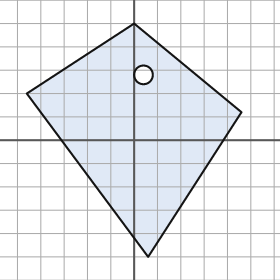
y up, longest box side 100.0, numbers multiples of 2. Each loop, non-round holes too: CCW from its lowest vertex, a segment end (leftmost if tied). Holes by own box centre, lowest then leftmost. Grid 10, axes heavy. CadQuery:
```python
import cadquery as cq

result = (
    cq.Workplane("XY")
    .moveTo(6.0, -50.0)
    .lineTo(46.0, 12.0)
    .lineTo(0.0, 50.0)
    .lineTo(-46.0, 20.0)
    .close()
    .moveTo(4.0, 28.0)
    .circle(4.0)
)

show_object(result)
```